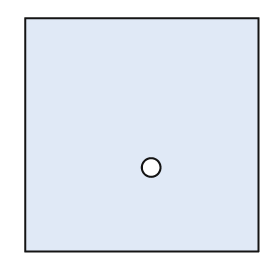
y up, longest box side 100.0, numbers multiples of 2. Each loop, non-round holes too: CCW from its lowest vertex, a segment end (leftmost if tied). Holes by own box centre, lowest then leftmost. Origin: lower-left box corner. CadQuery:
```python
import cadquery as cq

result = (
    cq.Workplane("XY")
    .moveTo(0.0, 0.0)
    .lineTo(100.0, 0.0)
    .lineTo(100.0, 100.0)
    .lineTo(0.0, 100.0)
    .close()
    .moveTo(54.0, 36.0)
    .circle(4.0)
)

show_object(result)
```